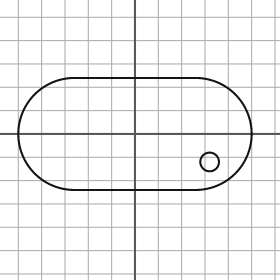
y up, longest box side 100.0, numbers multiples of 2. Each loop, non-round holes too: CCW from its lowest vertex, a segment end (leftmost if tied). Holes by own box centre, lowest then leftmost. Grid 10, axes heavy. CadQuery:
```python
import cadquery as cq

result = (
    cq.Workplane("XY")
    .moveTo(-26.0, -24.0)
    .lineTo(26.0, -24.0)
    .threePointArc((50.0, 0.0), (26.0, 24.0))
    .lineTo(-26.0, 24.0)
    .threePointArc((-50.0, 0.0), (-26.0, -24.0))
    .close()
    .moveTo(32.0, -12.0)
    .circle(4.0)
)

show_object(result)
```